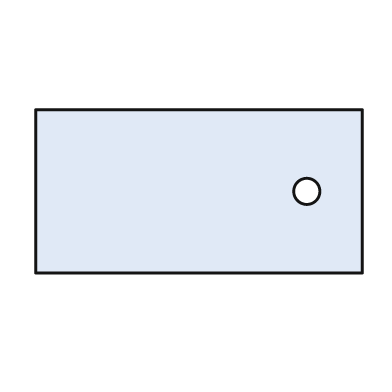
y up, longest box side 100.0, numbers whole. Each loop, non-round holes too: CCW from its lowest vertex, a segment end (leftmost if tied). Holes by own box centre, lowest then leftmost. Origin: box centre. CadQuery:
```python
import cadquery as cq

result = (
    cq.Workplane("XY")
    .moveTo(-50.0, -25.0)
    .lineTo(50.0, -25.0)
    .lineTo(50.0, 25.0)
    .lineTo(-50.0, 25.0)
    .close()
    .moveTo(33.0, 0.0)
    .circle(4.0)
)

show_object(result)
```